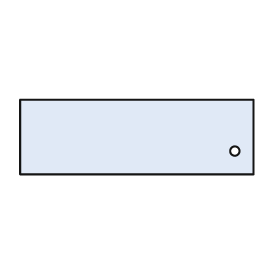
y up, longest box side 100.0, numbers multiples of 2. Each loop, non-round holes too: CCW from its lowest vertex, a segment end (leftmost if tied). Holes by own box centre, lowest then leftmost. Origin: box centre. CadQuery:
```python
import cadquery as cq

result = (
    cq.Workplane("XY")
    .moveTo(-50.0, -16.0)
    .lineTo(50.0, -16.0)
    .lineTo(50.0, 16.0)
    .lineTo(-50.0, 16.0)
    .close()
    .moveTo(42.0, -6.0)
    .circle(2.0)
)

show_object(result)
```